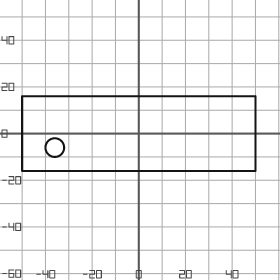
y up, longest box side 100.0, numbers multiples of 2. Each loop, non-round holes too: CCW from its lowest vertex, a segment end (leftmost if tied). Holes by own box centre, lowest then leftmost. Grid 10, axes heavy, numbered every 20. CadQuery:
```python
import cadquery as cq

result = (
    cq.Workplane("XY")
    .moveTo(-50.0, -16.0)
    .lineTo(50.0, -16.0)
    .lineTo(50.0, 16.0)
    .lineTo(-50.0, 16.0)
    .close()
    .moveTo(-36.0, -6.0)
    .circle(4.0)
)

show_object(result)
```